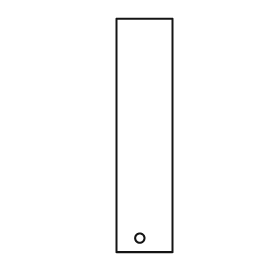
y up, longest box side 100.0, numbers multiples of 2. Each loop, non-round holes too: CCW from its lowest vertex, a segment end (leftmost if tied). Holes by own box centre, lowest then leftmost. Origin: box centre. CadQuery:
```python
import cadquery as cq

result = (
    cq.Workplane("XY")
    .moveTo(-12.0, -50.0)
    .lineTo(12.0, -50.0)
    .lineTo(12.0, 50.0)
    .lineTo(-12.0, 50.0)
    .close()
    .moveTo(-2.0, -44.0)
    .circle(2.0)
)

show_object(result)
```